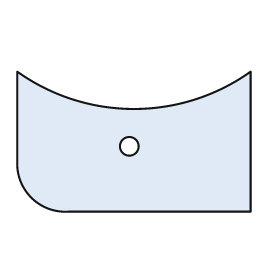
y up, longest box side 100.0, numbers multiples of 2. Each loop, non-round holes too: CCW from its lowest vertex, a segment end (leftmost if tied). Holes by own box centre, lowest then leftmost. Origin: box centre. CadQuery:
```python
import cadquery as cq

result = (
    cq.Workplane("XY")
    .moveTo(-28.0, -30.0)
    .lineTo(50.0, -30.0)
    .lineTo(50.0, 30.0)
    .threePointArc((0.0, 14.0), (-50.0, 30.0))
    .lineTo(-50.0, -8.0)
    .threePointArc((-44.0, -24.0), (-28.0, -30.0))
    .close()
    .moveTo(-2.0, -2.0)
    .circle(4.0)
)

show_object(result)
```